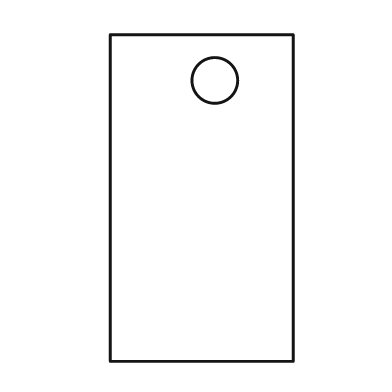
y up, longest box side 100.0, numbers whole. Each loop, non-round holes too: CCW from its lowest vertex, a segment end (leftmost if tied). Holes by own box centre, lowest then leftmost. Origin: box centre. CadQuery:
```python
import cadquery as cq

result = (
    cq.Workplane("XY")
    .moveTo(-28.0, -50.0)
    .lineTo(28.0, -50.0)
    .lineTo(28.0, 50.0)
    .lineTo(-28.0, 50.0)
    .close()
    .moveTo(4.0, 36.0)
    .circle(7.0)
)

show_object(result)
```